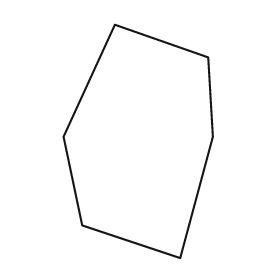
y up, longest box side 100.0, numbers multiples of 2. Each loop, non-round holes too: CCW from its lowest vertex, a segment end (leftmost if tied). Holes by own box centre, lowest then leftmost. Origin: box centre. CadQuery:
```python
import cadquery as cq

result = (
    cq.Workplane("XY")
    .moveTo(18.0, -50.0)
    .lineTo(32.0, 2.0)
    .lineTo(30.0, 36.0)
    .lineTo(-10.0, 50.0)
    .lineTo(-32.0, 2.0)
    .lineTo(-24.0, -36.0)
    .close()
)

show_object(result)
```